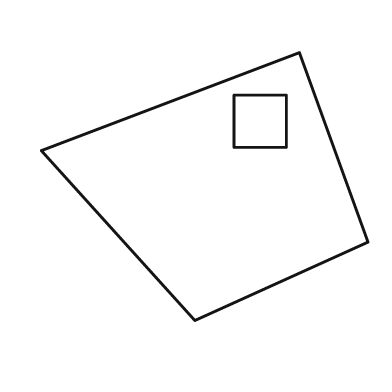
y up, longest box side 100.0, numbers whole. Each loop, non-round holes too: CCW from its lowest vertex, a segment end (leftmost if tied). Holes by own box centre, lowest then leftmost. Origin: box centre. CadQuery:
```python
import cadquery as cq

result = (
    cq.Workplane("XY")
    .moveTo(-3.0, -41.0)
    .lineTo(50.0, -17.0)
    .lineTo(29.0, 41.0)
    .lineTo(-50.0, 11.0)
    .close()
    .moveTo(9.0, 12.0)
    .lineTo(25.0, 12.0)
    .lineTo(25.0, 28.0)
    .lineTo(9.0, 28.0)
    .close()
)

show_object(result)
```